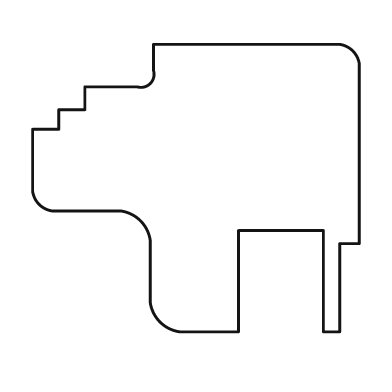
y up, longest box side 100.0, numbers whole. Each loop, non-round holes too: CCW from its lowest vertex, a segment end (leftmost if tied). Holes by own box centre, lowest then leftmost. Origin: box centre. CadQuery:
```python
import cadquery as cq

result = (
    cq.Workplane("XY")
    .moveTo(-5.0, -44.0)
    .lineTo(13.0, -44.0)
    .lineTo(13.0, -13.0)
    .lineTo(39.0, -13.0)
    .lineTo(39.0, -44.0)
    .lineTo(44.0, -44.0)
    .lineTo(44.0, -17.0)
    .lineTo(50.0, -17.0)
    .lineTo(50.0, 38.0)
    .threePointArc((48.0, 42.0), (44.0, 44.0))
    .lineTo(-13.0, 44.0)
    .lineTo(-13.0, 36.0)
    .threePointArc((-14.0, 32.0), (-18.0, 31.0))
    .lineTo(-34.0, 31.0)
    .lineTo(-34.0, 24.0)
    .lineTo(-42.0, 24.0)
    .lineTo(-42.0, 18.0)
    .lineTo(-50.0, 18.0)
    .lineTo(-50.0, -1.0)
    .threePointArc((-48.0, -5.0), (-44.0, -7.0))
    .lineTo(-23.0, -7.0)
    .threePointArc((-17.0, -10.0), (-14.0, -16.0))
    .lineTo(-14.0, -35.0)
    .threePointArc((-11.0, -41.0), (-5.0, -44.0))
    .close()
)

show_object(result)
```